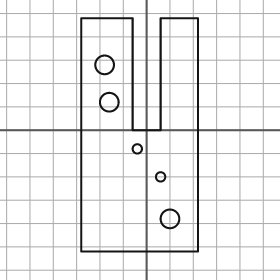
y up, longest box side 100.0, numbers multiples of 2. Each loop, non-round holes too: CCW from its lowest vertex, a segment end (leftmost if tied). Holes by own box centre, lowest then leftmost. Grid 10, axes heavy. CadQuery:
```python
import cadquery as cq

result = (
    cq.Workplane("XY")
    .moveTo(-28.0, -52.0)
    .lineTo(22.0, -52.0)
    .lineTo(22.0, 48.0)
    .lineTo(6.0, 48.0)
    .lineTo(6.0, 0.0)
    .lineTo(-6.0, 0.0)
    .lineTo(-6.0, 48.0)
    .lineTo(-28.0, 48.0)
    .close()
    .moveTo(10.0, -38.0)
    .circle(4.0)
    .moveTo(6.0, -20.0)
    .circle(2.0)
    .moveTo(-4.0, -8.0)
    .circle(2.0)
    .moveTo(-16.0, 12.0)
    .circle(4.0)
    .moveTo(-18.0, 28.0)
    .circle(4.0)
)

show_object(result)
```